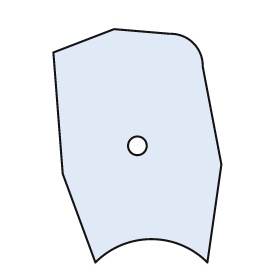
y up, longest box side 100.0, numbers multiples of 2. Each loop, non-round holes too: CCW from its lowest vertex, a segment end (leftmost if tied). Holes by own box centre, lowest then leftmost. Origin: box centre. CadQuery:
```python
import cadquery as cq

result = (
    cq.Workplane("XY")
    .moveTo(-18.0, -50.0)
    .threePointArc((6.0, -40.0), (30.0, -50.0))
    .lineTo(36.0, -8.0)
    .lineTo(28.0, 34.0)
    .threePointArc((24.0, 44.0), (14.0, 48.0))
    .lineTo(-10.0, 50.0)
    .lineTo(-36.0, 40.0)
    .lineTo(-32.0, -12.0)
    .close()
    .moveTo(0.0, 0.0)
    .circle(4.0)
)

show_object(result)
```